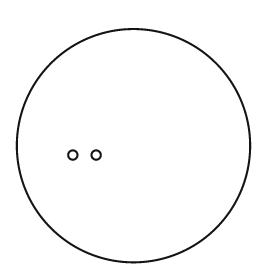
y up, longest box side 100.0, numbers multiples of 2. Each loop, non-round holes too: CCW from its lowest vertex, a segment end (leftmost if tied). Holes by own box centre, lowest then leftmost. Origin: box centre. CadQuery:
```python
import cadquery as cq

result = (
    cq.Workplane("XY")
    .moveTo(0.0, 0.0)
    .circle(50.0)
    .moveTo(-26.0, -4.0)
    .circle(2.0)
    .moveTo(-16.0, -4.0)
    .circle(2.0)
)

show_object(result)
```